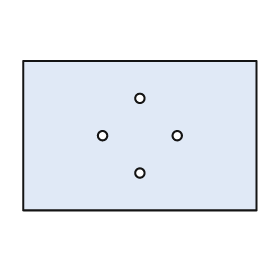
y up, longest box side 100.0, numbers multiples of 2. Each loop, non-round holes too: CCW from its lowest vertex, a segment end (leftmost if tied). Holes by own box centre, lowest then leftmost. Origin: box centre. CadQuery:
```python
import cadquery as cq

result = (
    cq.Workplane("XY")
    .moveTo(-50.0, -32.0)
    .lineTo(50.0, -32.0)
    .lineTo(50.0, 32.0)
    .lineTo(-50.0, 32.0)
    .close()
    .moveTo(0.0, -16.0)
    .circle(2.0)
    .moveTo(-16.0, 0.0)
    .circle(2.0)
    .moveTo(16.0, 0.0)
    .circle(2.0)
    .moveTo(0.0, 16.0)
    .circle(2.0)
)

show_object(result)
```